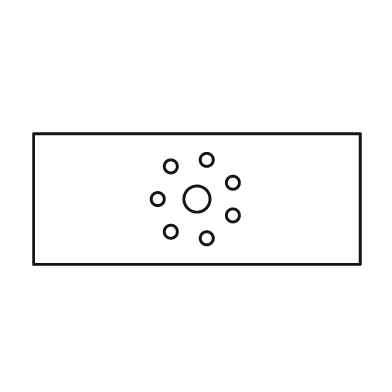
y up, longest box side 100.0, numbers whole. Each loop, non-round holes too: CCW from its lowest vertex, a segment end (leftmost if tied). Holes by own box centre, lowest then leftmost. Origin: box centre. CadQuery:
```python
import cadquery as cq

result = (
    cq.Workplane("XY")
    .moveTo(-50.0, -20.0)
    .lineTo(50.0, -20.0)
    .lineTo(50.0, 20.0)
    .lineTo(-50.0, 20.0)
    .close()
    .moveTo(3.0, -12.0)
    .circle(2.0)
    .moveTo(-8.0, -10.0)
    .circle(2.0)
    .moveTo(11.0, -5.0)
    .circle(2.0)
    .moveTo(-12.0, 0.0)
    .circle(2.0)
    .moveTo(0.0, 0.0)
    .circle(4.0)
    .moveTo(11.0, 5.0)
    .circle(2.0)
    .moveTo(-8.0, 10.0)
    .circle(2.0)
    .moveTo(3.0, 12.0)
    .circle(2.0)
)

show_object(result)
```